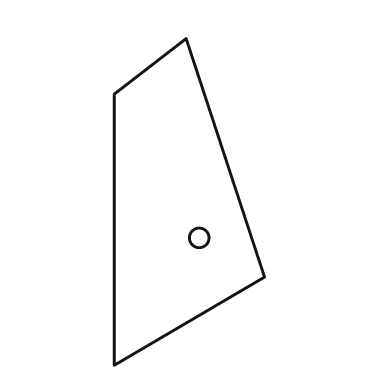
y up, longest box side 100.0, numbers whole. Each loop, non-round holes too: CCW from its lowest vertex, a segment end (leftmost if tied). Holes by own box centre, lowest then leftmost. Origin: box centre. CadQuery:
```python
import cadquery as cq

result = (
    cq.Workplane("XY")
    .moveTo(-23.0, -50.0)
    .lineTo(23.0, -23.0)
    .lineTo(-1.0, 50.0)
    .lineTo(-23.0, 33.0)
    .close()
    .moveTo(3.0, -11.0)
    .circle(3.0)
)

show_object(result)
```